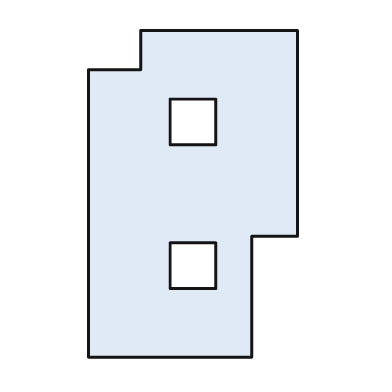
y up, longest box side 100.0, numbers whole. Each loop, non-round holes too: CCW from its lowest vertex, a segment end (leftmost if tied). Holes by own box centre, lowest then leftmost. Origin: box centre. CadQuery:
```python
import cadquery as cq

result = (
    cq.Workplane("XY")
    .moveTo(-32.0, -50.0)
    .lineTo(18.0, -50.0)
    .lineTo(18.0, -13.0)
    .lineTo(32.0, -13.0)
    .lineTo(32.0, 50.0)
    .lineTo(-16.0, 50.0)
    .lineTo(-16.0, 38.0)
    .lineTo(-32.0, 38.0)
    .close()
    .moveTo(-7.0, -29.0)
    .lineTo(7.0, -29.0)
    .lineTo(7.0, -15.0)
    .lineTo(-7.0, -15.0)
    .close()
    .moveTo(-7.0, 15.0)
    .lineTo(7.0, 15.0)
    .lineTo(7.0, 29.0)
    .lineTo(-7.0, 29.0)
    .close()
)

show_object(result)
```